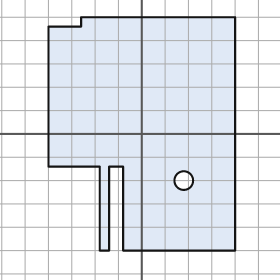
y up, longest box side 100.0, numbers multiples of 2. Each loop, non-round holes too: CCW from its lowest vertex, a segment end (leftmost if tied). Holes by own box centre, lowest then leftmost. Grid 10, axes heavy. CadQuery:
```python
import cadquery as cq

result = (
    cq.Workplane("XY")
    .moveTo(-18.0, -50.0)
    .lineTo(-14.0, -50.0)
    .lineTo(-14.0, -14.0)
    .lineTo(-8.0, -14.0)
    .lineTo(-8.0, -50.0)
    .lineTo(40.0, -50.0)
    .lineTo(40.0, 50.0)
    .lineTo(-26.0, 50.0)
    .lineTo(-26.0, 46.0)
    .lineTo(-40.0, 46.0)
    .lineTo(-40.0, -14.0)
    .lineTo(-18.0, -14.0)
    .close()
    .moveTo(18.0, -20.0)
    .circle(4.0)
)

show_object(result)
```